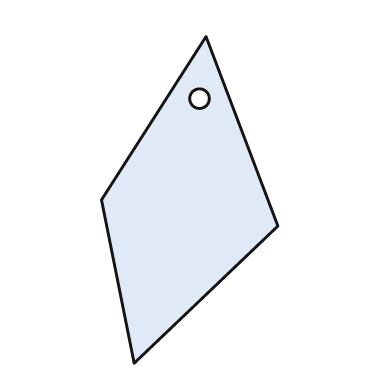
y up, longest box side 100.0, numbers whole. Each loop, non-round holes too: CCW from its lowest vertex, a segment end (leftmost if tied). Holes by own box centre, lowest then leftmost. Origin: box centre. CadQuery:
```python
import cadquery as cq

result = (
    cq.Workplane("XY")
    .moveTo(-17.0, -50.0)
    .lineTo(27.0, -8.0)
    .lineTo(5.0, 50.0)
    .lineTo(-27.0, 0.0)
    .close()
    .moveTo(3.0, 31.0)
    .circle(3.0)
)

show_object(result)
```